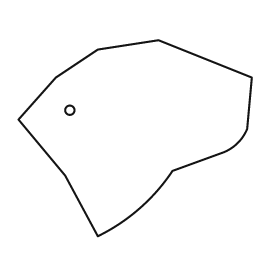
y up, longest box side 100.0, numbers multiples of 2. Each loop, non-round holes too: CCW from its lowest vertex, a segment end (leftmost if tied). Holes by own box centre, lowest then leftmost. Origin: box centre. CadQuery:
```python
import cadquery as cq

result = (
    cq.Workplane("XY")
    .moveTo(-16.0, -42.0)
    .threePointArc((2.0, -30.0), (16.0, -14.0))
    .lineTo(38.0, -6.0)
    .threePointArc((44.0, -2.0), (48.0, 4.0))
    .lineTo(50.0, 26.0)
    .lineTo(10.0, 42.0)
    .lineTo(-16.0, 38.0)
    .lineTo(-34.0, 26.0)
    .lineTo(-50.0, 8.0)
    .lineTo(-30.0, -16.0)
    .close()
    .moveTo(-28.0, 12.0)
    .circle(2.0)
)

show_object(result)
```